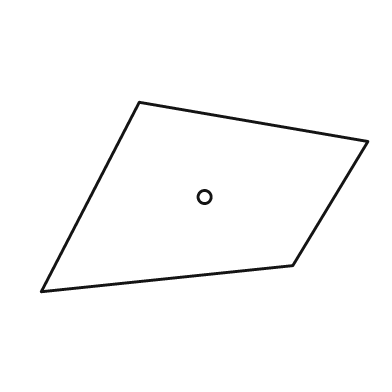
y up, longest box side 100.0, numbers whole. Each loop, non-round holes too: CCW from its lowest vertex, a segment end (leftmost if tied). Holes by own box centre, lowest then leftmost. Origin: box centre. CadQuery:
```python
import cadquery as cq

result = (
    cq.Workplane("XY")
    .moveTo(-50.0, -29.0)
    .lineTo(27.0, -21.0)
    .lineTo(50.0, 17.0)
    .lineTo(-20.0, 29.0)
    .close()
    .moveTo(0.0, 0.0)
    .circle(2.0)
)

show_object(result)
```